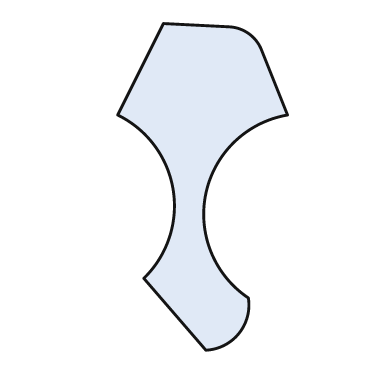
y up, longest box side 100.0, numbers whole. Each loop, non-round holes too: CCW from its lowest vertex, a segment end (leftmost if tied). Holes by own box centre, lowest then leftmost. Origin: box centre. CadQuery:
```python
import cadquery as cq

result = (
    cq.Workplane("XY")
    .moveTo(1.0, -50.0)
    .threePointArc((11.0, -45.0), (14.0, -34.0))
    .threePointArc((1.0, -2.0), (26.0, 22.0))
    .lineTo(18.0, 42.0)
    .threePointArc((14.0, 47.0), (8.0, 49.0))
    .lineTo(-12.0, 50.0)
    .lineTo(-26.0, 22.0)
    .threePointArc((-9.0, -1.0), (-18.0, -28.0))
    .close()
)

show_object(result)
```